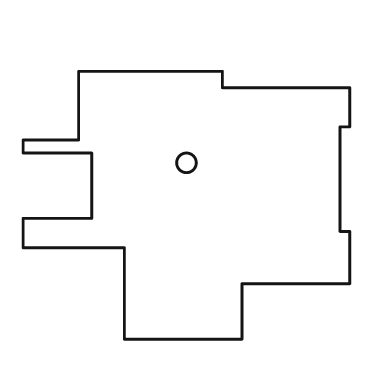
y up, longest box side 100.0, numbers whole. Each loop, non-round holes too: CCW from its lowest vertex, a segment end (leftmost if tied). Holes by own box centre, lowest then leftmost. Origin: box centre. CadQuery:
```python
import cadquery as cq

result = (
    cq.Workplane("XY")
    .moveTo(-19.0, -41.0)
    .lineTo(17.0, -41.0)
    .lineTo(17.0, -24.0)
    .lineTo(50.0, -24.0)
    .lineTo(50.0, -8.0)
    .lineTo(47.0, -8.0)
    .lineTo(47.0, 24.0)
    .lineTo(50.0, 24.0)
    .lineTo(50.0, 36.0)
    .lineTo(11.0, 36.0)
    .lineTo(11.0, 41.0)
    .lineTo(-33.0, 41.0)
    .lineTo(-33.0, 20.0)
    .lineTo(-50.0, 20.0)
    .lineTo(-50.0, 16.0)
    .lineTo(-29.0, 16.0)
    .lineTo(-29.0, -4.0)
    .lineTo(-50.0, -4.0)
    .lineTo(-50.0, -13.0)
    .lineTo(-19.0, -13.0)
    .close()
    .moveTo(0.0, 13.0)
    .circle(3.0)
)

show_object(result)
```